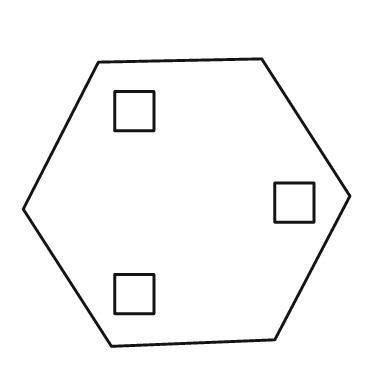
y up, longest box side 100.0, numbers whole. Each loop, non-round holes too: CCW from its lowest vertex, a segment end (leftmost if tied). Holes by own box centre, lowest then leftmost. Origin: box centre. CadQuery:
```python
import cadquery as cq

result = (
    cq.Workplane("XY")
    .moveTo(-23.0, -44.0)
    .lineTo(27.0, -42.0)
    .lineTo(50.0, 2.0)
    .lineTo(23.0, 44.0)
    .lineTo(-27.0, 43.0)
    .lineTo(-50.0, -2.0)
    .close()
    .moveTo(-22.0, -34.0)
    .lineTo(-10.0, -34.0)
    .lineTo(-10.0, -22.0)
    .lineTo(-22.0, -22.0)
    .close()
    .moveTo(27.0, -6.0)
    .lineTo(39.0, -6.0)
    .lineTo(39.0, 6.0)
    .lineTo(27.0, 6.0)
    .close()
    .moveTo(-22.0, 22.0)
    .lineTo(-10.0, 22.0)
    .lineTo(-10.0, 34.0)
    .lineTo(-22.0, 34.0)
    .close()
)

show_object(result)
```